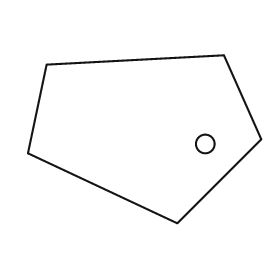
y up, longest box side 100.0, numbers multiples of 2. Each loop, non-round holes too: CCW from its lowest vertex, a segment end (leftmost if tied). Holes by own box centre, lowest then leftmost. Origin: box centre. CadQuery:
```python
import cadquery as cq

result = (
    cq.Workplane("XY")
    .moveTo(14.0, -36.0)
    .lineTo(50.0, 0.0)
    .lineTo(34.0, 36.0)
    .lineTo(-42.0, 32.0)
    .lineTo(-50.0, -6.0)
    .close()
    .moveTo(26.0, -2.0)
    .circle(4.0)
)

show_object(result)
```